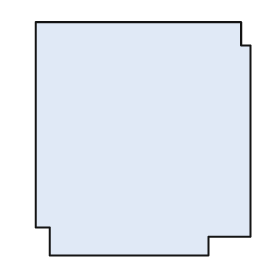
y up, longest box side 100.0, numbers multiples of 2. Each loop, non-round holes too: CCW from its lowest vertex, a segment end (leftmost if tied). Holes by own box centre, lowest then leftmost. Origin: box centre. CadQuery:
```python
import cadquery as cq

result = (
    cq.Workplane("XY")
    .moveTo(-40.0, -50.0)
    .lineTo(28.0, -50.0)
    .lineTo(28.0, -42.0)
    .lineTo(46.0, -42.0)
    .lineTo(46.0, 40.0)
    .lineTo(42.0, 40.0)
    .lineTo(42.0, 50.0)
    .lineTo(-46.0, 50.0)
    .lineTo(-46.0, -38.0)
    .lineTo(-40.0, -38.0)
    .close()
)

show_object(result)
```